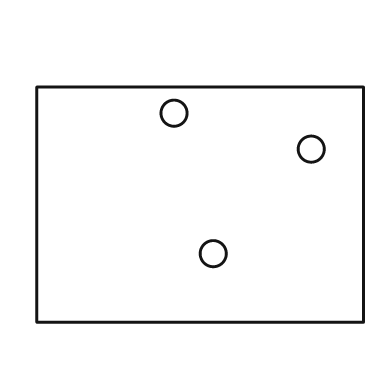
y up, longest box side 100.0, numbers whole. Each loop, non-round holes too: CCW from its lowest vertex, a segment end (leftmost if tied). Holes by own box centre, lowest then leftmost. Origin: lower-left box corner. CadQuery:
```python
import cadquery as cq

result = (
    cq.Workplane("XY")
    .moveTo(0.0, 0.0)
    .lineTo(100.0, 0.0)
    .lineTo(100.0, 72.0)
    .lineTo(0.0, 72.0)
    .close()
    .moveTo(54.0, 21.0)
    .circle(4.0)
    .moveTo(84.0, 53.0)
    .circle(4.0)
    .moveTo(42.0, 64.0)
    .circle(4.0)
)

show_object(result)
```